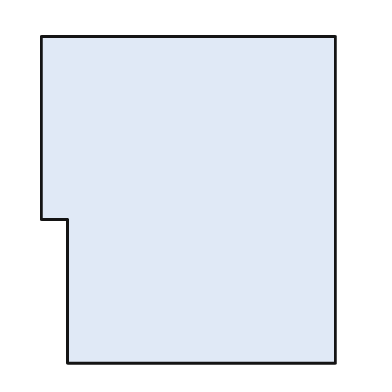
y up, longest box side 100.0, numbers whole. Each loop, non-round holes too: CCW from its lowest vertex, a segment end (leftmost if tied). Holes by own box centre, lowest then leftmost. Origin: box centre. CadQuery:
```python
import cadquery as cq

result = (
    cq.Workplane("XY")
    .moveTo(-37.0, -50.0)
    .lineTo(45.0, -50.0)
    .lineTo(45.0, 50.0)
    .lineTo(-45.0, 50.0)
    .lineTo(-45.0, -6.0)
    .lineTo(-37.0, -6.0)
    .close()
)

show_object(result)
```